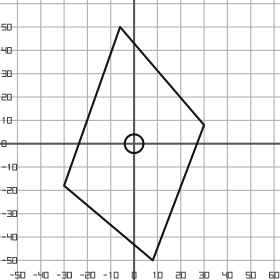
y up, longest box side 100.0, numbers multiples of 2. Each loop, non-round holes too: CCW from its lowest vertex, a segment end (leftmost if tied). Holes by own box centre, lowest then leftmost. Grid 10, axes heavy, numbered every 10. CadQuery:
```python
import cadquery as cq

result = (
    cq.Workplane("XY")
    .moveTo(8.0, -50.0)
    .lineTo(30.0, 8.0)
    .lineTo(-6.0, 50.0)
    .lineTo(-30.0, -18.0)
    .close()
    .moveTo(0.0, 0.0)
    .circle(4.0)
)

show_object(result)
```